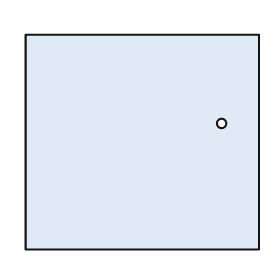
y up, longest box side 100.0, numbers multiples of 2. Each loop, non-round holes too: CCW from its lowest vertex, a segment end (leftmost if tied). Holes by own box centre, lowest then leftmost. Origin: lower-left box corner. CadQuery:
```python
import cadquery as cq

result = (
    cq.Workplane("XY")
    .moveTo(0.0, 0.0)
    .lineTo(100.0, 0.0)
    .lineTo(100.0, 92.0)
    .lineTo(0.0, 92.0)
    .close()
    .moveTo(84.0, 54.0)
    .circle(2.0)
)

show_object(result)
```